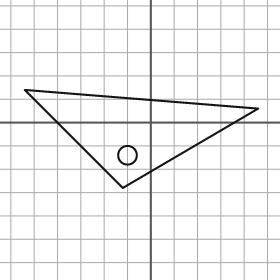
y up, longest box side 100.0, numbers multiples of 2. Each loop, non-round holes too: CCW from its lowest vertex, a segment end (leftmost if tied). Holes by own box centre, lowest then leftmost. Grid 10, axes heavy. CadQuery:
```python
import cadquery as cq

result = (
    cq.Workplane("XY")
    .moveTo(-12.0, -28.0)
    .lineTo(46.0, 6.0)
    .lineTo(-54.0, 14.0)
    .close()
    .moveTo(-10.0, -14.0)
    .circle(4.0)
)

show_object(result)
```